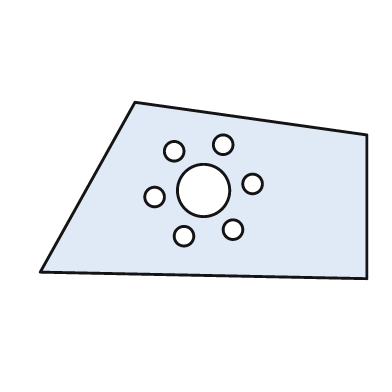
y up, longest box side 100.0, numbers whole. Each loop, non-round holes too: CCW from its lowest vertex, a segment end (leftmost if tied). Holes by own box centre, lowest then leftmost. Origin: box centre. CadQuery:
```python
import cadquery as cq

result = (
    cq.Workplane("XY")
    .moveTo(50.0, -27.0)
    .lineTo(50.0, 17.0)
    .lineTo(-21.0, 27.0)
    .lineTo(-50.0, -25.0)
    .close()
    .moveTo(-6.0, -14.0)
    .circle(3.0)
    .moveTo(9.0, -12.0)
    .circle(3.0)
    .moveTo(-15.0, -2.0)
    .circle(3.0)
    .moveTo(0.0, 0.0)
    .circle(8.0)
    .moveTo(15.0, 2.0)
    .circle(3.0)
    .moveTo(-9.0, 12.0)
    .circle(3.0)
    .moveTo(6.0, 14.0)
    .circle(3.0)
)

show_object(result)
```